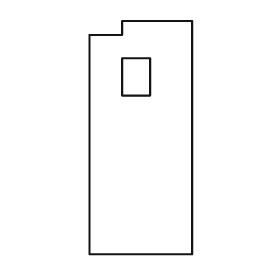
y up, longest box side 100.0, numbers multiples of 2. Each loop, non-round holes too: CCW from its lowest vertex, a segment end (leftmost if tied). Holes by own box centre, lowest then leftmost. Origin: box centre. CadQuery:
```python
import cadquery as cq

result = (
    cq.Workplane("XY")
    .moveTo(-22.0, -50.0)
    .lineTo(22.0, -50.0)
    .lineTo(22.0, 50.0)
    .lineTo(-8.0, 50.0)
    .lineTo(-8.0, 44.0)
    .lineTo(-22.0, 44.0)
    .close()
    .moveTo(-8.0, 18.0)
    .lineTo(4.0, 18.0)
    .lineTo(4.0, 34.0)
    .lineTo(-8.0, 34.0)
    .close()
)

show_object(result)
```